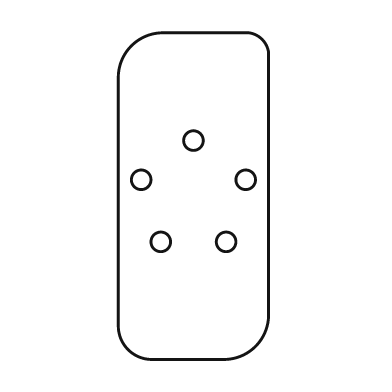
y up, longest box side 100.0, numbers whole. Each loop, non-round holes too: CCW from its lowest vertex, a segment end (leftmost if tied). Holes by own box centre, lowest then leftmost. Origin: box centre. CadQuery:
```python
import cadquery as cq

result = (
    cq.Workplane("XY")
    .moveTo(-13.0, -50.0)
    .lineTo(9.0, -50.0)
    .threePointArc((19.0, -46.0), (23.0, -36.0))
    .lineTo(23.0, 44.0)
    .threePointArc((21.0, 48.0), (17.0, 50.0))
    .lineTo(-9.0, 50.0)
    .threePointArc((-19.0, 46.0), (-23.0, 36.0))
    .lineTo(-23.0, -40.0)
    .threePointArc((-20.0, -47.0), (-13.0, -50.0))
    .close()
    .moveTo(-10.0, -14.0)
    .circle(3.0)
    .moveTo(10.0, -14.0)
    .circle(3.0)
    .moveTo(-16.0, 5.0)
    .circle(3.0)
    .moveTo(16.0, 5.0)
    .circle(3.0)
    .moveTo(0.0, 17.0)
    .circle(3.0)
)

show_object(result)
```